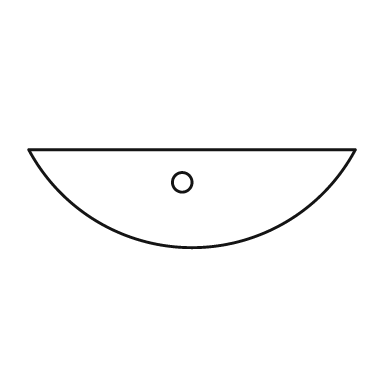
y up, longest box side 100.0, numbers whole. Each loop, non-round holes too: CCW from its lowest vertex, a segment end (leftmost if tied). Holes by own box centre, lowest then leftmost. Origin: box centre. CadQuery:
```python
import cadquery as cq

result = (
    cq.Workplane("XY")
    .moveTo(-50.0, 15.0)
    .threePointArc((0.0, -15.0), (50.0, 15.0))
    .close()
    .moveTo(-3.0, 5.0)
    .circle(3.0)
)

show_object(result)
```